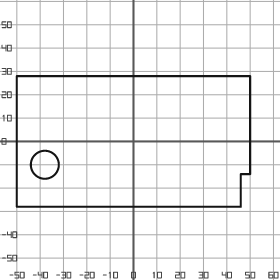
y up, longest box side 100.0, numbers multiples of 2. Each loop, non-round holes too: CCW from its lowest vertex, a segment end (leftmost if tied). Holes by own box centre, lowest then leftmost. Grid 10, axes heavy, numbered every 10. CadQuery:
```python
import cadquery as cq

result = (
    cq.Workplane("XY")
    .moveTo(-50.0, -28.0)
    .lineTo(46.0, -28.0)
    .lineTo(46.0, -14.0)
    .lineTo(50.0, -14.0)
    .lineTo(50.0, 28.0)
    .lineTo(-50.0, 28.0)
    .close()
    .moveTo(-38.0, -10.0)
    .circle(6.0)
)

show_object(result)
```